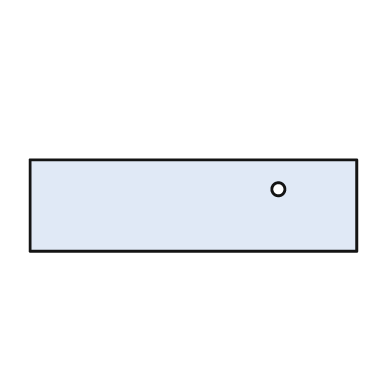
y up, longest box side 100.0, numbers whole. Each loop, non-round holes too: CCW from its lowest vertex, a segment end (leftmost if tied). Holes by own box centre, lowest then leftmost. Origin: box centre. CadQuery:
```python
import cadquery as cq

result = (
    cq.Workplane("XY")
    .moveTo(-50.0, -14.0)
    .lineTo(50.0, -14.0)
    .lineTo(50.0, 14.0)
    .lineTo(-50.0, 14.0)
    .close()
    .moveTo(26.0, 5.0)
    .circle(2.0)
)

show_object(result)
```